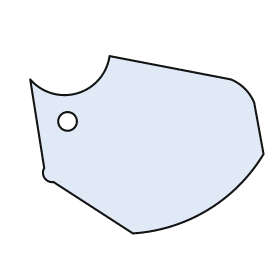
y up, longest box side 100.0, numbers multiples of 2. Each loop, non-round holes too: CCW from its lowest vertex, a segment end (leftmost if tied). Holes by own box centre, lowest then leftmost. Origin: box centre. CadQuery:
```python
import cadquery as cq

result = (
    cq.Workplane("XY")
    .moveTo(-6.0, -38.0)
    .threePointArc((26.0, -28.0), (50.0, -4.0))
    .lineTo(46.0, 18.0)
    .threePointArc((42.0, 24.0), (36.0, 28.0))
    .lineTo(-16.0, 38.0)
    .threePointArc((-30.0, 22.0), (-50.0, 28.0))
    .lineTo(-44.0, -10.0)
    .threePointArc((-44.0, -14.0), (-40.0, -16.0))
    .close()
    .moveTo(-34.0, 10.0)
    .circle(4.0)
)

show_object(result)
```